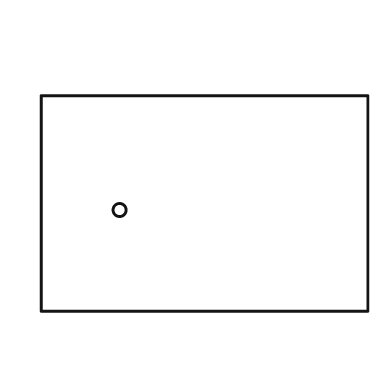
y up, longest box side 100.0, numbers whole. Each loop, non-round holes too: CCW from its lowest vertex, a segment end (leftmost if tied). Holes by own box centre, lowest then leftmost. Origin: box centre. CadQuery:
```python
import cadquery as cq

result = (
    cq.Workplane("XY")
    .moveTo(-50.0, -33.0)
    .lineTo(50.0, -33.0)
    .lineTo(50.0, 33.0)
    .lineTo(-50.0, 33.0)
    .close()
    .moveTo(-26.0, -2.0)
    .circle(2.0)
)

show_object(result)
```